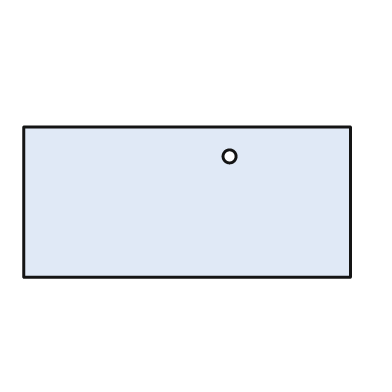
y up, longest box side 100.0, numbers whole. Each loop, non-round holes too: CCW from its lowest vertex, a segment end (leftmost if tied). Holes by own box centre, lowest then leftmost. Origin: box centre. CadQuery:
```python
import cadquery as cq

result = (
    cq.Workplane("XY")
    .moveTo(-50.0, -23.0)
    .lineTo(50.0, -23.0)
    .lineTo(50.0, 23.0)
    .lineTo(-50.0, 23.0)
    .close()
    .moveTo(13.0, 14.0)
    .circle(2.0)
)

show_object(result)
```